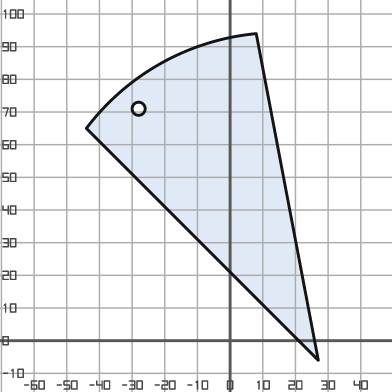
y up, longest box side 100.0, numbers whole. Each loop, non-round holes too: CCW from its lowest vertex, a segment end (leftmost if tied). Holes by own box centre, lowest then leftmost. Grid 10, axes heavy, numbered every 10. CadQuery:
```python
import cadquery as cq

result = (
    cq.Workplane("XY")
    .moveTo(27.0, -6.0)
    .lineTo(8.0, 94.0)
    .threePointArc((-21.0, 85.0), (-44.0, 65.0))
    .close()
    .moveTo(-28.0, 71.0)
    .circle(2.0)
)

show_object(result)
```